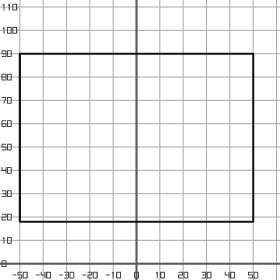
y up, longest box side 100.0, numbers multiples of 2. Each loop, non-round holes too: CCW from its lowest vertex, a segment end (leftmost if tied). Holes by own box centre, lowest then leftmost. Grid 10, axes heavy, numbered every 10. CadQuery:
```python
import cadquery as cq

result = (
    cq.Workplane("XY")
    .moveTo(-50.0, 18.0)
    .lineTo(50.0, 18.0)
    .lineTo(50.0, 90.0)
    .lineTo(-50.0, 90.0)
    .close()
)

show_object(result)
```